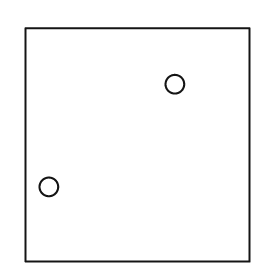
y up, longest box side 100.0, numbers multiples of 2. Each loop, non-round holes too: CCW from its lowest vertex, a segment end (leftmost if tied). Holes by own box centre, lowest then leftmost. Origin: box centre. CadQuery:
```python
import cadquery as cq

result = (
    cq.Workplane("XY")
    .moveTo(-48.0, -50.0)
    .lineTo(48.0, -50.0)
    .lineTo(48.0, 50.0)
    .lineTo(-48.0, 50.0)
    .close()
    .moveTo(-38.0, -18.0)
    .circle(4.0)
    .moveTo(16.0, 26.0)
    .circle(4.0)
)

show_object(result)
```